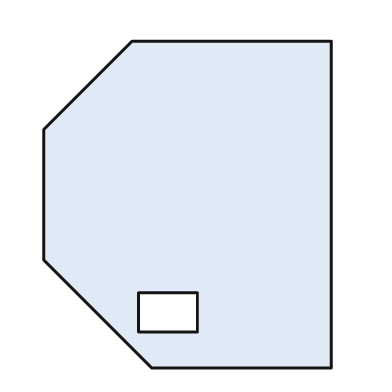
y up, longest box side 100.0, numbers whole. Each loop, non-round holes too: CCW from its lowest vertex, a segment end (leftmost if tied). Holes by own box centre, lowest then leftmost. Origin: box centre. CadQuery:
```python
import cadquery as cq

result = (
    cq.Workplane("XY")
    .moveTo(-11.0, -50.0)
    .lineTo(44.0, -50.0)
    .lineTo(44.0, 50.0)
    .lineTo(-17.0, 50.0)
    .lineTo(-44.0, 23.0)
    .lineTo(-44.0, -17.0)
    .close()
    .moveTo(-15.0, -39.0)
    .lineTo(3.0, -39.0)
    .lineTo(3.0, -27.0)
    .lineTo(-15.0, -27.0)
    .close()
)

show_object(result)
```